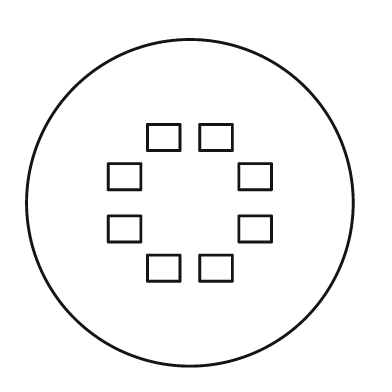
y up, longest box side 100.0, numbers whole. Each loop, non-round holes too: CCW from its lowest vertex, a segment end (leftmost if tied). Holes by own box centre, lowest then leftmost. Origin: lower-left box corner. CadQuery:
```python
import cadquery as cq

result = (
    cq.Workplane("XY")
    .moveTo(50.0, 50.0)
    .circle(50.0)
    .moveTo(37.0, 26.0)
    .lineTo(47.0, 26.0)
    .lineTo(47.0, 34.0)
    .lineTo(37.0, 34.0)
    .close()
    .moveTo(53.0, 26.0)
    .lineTo(63.0, 26.0)
    .lineTo(63.0, 34.0)
    .lineTo(53.0, 34.0)
    .close()
    .moveTo(25.0, 38.0)
    .lineTo(35.0, 38.0)
    .lineTo(35.0, 46.0)
    .lineTo(25.0, 46.0)
    .close()
    .moveTo(65.0, 38.0)
    .lineTo(75.0, 38.0)
    .lineTo(75.0, 46.0)
    .lineTo(65.0, 46.0)
    .close()
    .moveTo(25.0, 54.0)
    .lineTo(35.0, 54.0)
    .lineTo(35.0, 62.0)
    .lineTo(25.0, 62.0)
    .close()
    .moveTo(65.0, 54.0)
    .lineTo(75.0, 54.0)
    .lineTo(75.0, 62.0)
    .lineTo(65.0, 62.0)
    .close()
    .moveTo(37.0, 66.0)
    .lineTo(47.0, 66.0)
    .lineTo(47.0, 74.0)
    .lineTo(37.0, 74.0)
    .close()
    .moveTo(53.0, 66.0)
    .lineTo(63.0, 66.0)
    .lineTo(63.0, 74.0)
    .lineTo(53.0, 74.0)
    .close()
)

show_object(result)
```